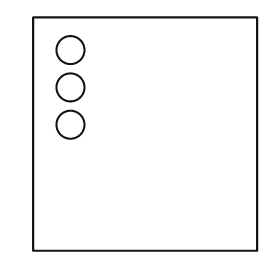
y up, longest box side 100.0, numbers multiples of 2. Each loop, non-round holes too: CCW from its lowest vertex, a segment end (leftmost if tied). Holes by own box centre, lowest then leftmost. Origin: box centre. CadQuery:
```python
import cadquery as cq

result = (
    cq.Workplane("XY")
    .moveTo(-48.0, -50.0)
    .lineTo(48.0, -50.0)
    .lineTo(48.0, 50.0)
    .lineTo(-48.0, 50.0)
    .close()
    .moveTo(-32.0, 4.0)
    .circle(6.0)
    .moveTo(-32.0, 20.0)
    .circle(6.0)
    .moveTo(-32.0, 36.0)
    .circle(6.0)
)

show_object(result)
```